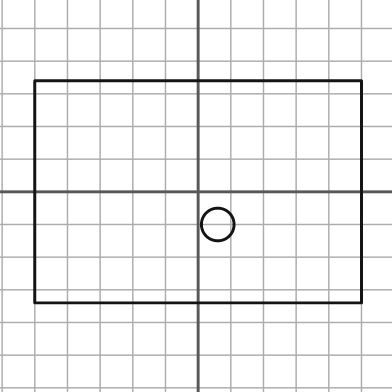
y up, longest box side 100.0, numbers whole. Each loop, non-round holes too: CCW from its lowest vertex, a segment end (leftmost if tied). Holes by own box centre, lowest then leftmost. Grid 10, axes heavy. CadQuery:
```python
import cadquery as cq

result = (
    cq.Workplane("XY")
    .moveTo(-50.0, -34.0)
    .lineTo(50.0, -34.0)
    .lineTo(50.0, 34.0)
    .lineTo(-50.0, 34.0)
    .close()
    .moveTo(6.0, -10.0)
    .circle(5.0)
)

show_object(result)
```